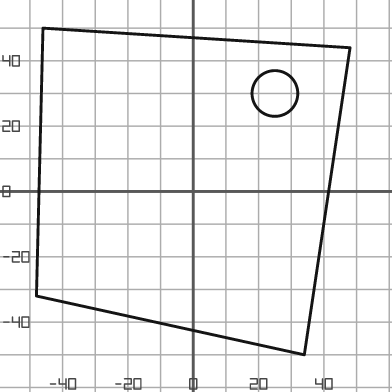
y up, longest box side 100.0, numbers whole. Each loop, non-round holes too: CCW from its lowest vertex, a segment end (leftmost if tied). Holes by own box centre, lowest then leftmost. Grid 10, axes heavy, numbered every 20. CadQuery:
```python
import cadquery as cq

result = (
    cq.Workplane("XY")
    .moveTo(34.0, -50.0)
    .lineTo(48.0, 44.0)
    .lineTo(-46.0, 50.0)
    .lineTo(-48.0, -32.0)
    .close()
    .moveTo(25.0, 30.0)
    .circle(7.0)
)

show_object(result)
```